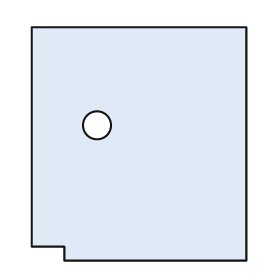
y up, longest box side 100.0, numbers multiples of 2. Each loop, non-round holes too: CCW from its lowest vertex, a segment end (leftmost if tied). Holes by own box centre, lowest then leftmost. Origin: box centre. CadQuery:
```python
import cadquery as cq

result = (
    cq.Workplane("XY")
    .moveTo(-32.0, -50.0)
    .lineTo(46.0, -50.0)
    .lineTo(46.0, 50.0)
    .lineTo(-46.0, 50.0)
    .lineTo(-46.0, -44.0)
    .lineTo(-32.0, -44.0)
    .close()
    .moveTo(-18.0, 8.0)
    .circle(6.0)
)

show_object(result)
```